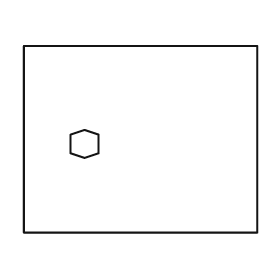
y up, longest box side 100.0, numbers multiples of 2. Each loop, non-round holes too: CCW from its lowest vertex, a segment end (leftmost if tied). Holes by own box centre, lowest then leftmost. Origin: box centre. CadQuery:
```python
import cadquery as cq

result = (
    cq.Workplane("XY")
    .moveTo(-50.0, -40.0)
    .lineTo(50.0, -40.0)
    .lineTo(50.0, 40.0)
    .lineTo(-50.0, 40.0)
    .close()
    .moveTo(-24.0, -8.0)
    .lineTo(-18.0, -6.0)
    .lineTo(-18.0, 2.0)
    .lineTo(-24.0, 4.0)
    .lineTo(-30.0, 2.0)
    .lineTo(-30.0, -6.0)
    .close()
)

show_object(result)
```